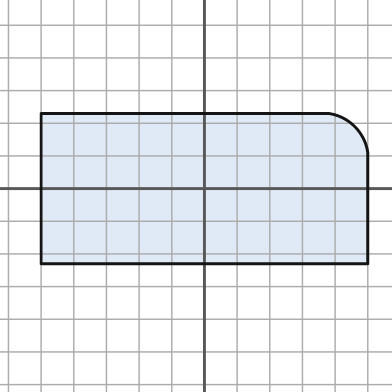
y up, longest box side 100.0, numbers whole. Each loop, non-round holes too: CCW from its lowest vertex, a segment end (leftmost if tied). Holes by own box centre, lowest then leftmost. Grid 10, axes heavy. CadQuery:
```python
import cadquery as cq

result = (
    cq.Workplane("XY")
    .moveTo(-50.0, -23.0)
    .lineTo(50.0, -23.0)
    .lineTo(50.0, 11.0)
    .threePointArc((46.0, 19.0), (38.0, 23.0))
    .lineTo(-50.0, 23.0)
    .close()
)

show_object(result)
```